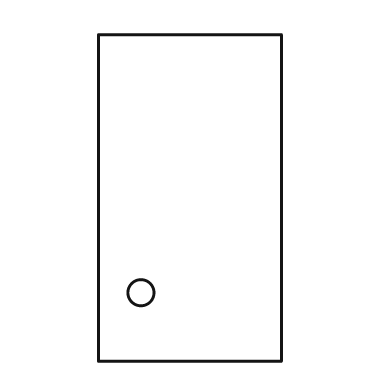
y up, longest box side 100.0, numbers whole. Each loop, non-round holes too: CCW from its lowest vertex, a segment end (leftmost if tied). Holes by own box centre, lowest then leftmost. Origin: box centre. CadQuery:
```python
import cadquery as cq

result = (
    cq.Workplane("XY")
    .moveTo(-28.0, -50.0)
    .lineTo(28.0, -50.0)
    .lineTo(28.0, 50.0)
    .lineTo(-28.0, 50.0)
    .close()
    .moveTo(-15.0, -29.0)
    .circle(4.0)
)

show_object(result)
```